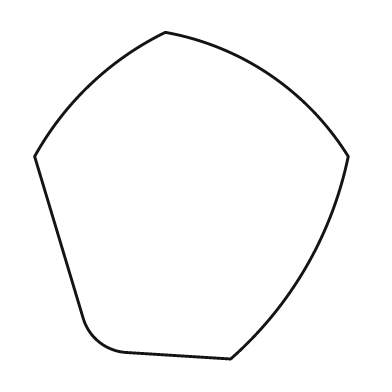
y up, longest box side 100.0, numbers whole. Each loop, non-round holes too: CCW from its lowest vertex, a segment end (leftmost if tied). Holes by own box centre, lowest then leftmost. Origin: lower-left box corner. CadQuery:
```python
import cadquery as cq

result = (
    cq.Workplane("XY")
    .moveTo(60.0, 0.0)
    .threePointArc((83.0, 28.0), (96.0, 62.0))
    .threePointArc((72.0, 87.0), (40.0, 100.0))
    .threePointArc((17.0, 84.0), (0.0, 62.0))
    .lineTo(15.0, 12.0)
    .threePointArc((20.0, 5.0), (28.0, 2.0))
    .close()
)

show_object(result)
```